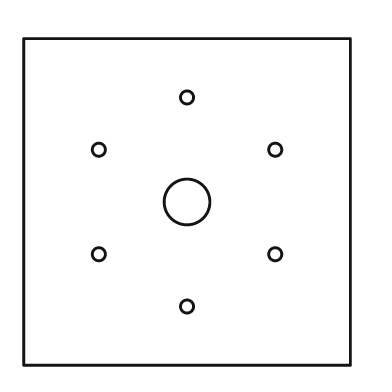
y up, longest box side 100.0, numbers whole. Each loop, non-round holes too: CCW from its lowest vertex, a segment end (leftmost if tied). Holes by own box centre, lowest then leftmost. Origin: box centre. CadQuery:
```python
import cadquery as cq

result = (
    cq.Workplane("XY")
    .moveTo(-50.0, -50.0)
    .lineTo(50.0, -50.0)
    .lineTo(50.0, 50.0)
    .lineTo(-50.0, 50.0)
    .close()
    .moveTo(0.0, -32.0)
    .circle(2.0)
    .moveTo(-27.0, -16.0)
    .circle(2.0)
    .moveTo(27.0, -16.0)
    .circle(2.0)
    .moveTo(0.0, 0.0)
    .circle(7.0)
    .moveTo(-27.0, 16.0)
    .circle(2.0)
    .moveTo(27.0, 16.0)
    .circle(2.0)
    .moveTo(0.0, 32.0)
    .circle(2.0)
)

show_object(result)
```